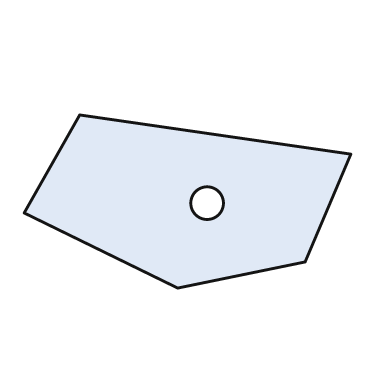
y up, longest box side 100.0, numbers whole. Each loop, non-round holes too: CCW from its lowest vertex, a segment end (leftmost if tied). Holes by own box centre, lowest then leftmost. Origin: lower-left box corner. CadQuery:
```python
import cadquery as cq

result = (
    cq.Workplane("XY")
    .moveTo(47.0, 0.0)
    .lineTo(86.0, 8.0)
    .lineTo(100.0, 41.0)
    .lineTo(17.0, 53.0)
    .lineTo(0.0, 23.0)
    .close()
    .moveTo(56.0, 26.0)
    .circle(5.0)
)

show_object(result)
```